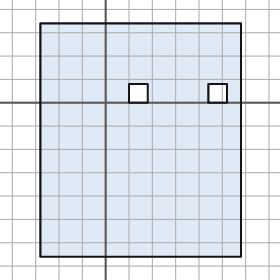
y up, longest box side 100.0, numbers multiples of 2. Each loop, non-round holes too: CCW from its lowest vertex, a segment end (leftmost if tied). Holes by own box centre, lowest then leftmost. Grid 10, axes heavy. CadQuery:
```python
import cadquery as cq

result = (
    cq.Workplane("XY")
    .moveTo(-28.0, -66.0)
    .lineTo(58.0, -66.0)
    .lineTo(58.0, 34.0)
    .lineTo(-28.0, 34.0)
    .close()
    .moveTo(10.0, 0.0)
    .lineTo(18.0, 0.0)
    .lineTo(18.0, 8.0)
    .lineTo(10.0, 8.0)
    .close()
    .moveTo(44.0, 0.0)
    .lineTo(52.0, 0.0)
    .lineTo(52.0, 8.0)
    .lineTo(44.0, 8.0)
    .close()
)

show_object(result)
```